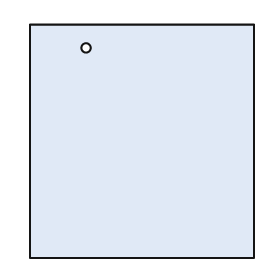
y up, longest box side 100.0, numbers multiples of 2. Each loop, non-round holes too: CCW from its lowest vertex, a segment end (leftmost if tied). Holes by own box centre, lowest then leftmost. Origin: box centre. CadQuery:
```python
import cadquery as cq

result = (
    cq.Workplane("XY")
    .moveTo(-48.0, -50.0)
    .lineTo(48.0, -50.0)
    .lineTo(48.0, 50.0)
    .lineTo(-48.0, 50.0)
    .close()
    .moveTo(-24.0, 40.0)
    .circle(2.0)
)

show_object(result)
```